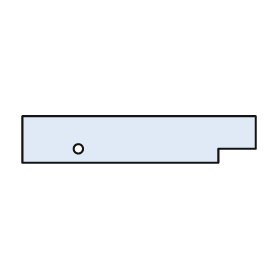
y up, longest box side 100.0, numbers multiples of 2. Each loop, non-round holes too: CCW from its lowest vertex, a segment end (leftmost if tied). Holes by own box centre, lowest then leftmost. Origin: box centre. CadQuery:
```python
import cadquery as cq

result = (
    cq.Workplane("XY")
    .moveTo(-50.0, -10.0)
    .lineTo(34.0, -10.0)
    .lineTo(34.0, -4.0)
    .lineTo(50.0, -4.0)
    .lineTo(50.0, 10.0)
    .lineTo(-50.0, 10.0)
    .close()
    .moveTo(-26.0, -4.0)
    .circle(2.0)
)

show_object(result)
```